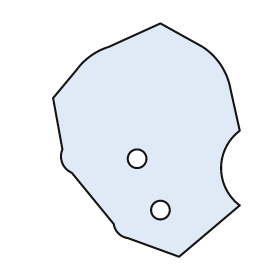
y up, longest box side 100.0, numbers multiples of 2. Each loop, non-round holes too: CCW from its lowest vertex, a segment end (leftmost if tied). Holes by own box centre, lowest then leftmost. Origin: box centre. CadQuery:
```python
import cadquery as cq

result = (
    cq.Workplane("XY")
    .moveTo(14.0, -50.0)
    .lineTo(40.0, -28.0)
    .threePointArc((32.0, -12.0), (40.0, 4.0))
    .lineTo(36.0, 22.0)
    .threePointArc((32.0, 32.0), (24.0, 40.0))
    .lineTo(6.0, 50.0)
    .lineTo(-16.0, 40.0)
    .threePointArc((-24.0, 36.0), (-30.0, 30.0))
    .lineTo(-40.0, 18.0)
    .lineTo(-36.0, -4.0)
    .threePointArc((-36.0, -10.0), (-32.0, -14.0))
    .lineTo(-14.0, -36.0)
    .threePointArc((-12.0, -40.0), (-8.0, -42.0))
    .close()
    .moveTo(6.0, -30.0)
    .circle(4.0)
    .moveTo(-4.0, -8.0)
    .circle(4.0)
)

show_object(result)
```